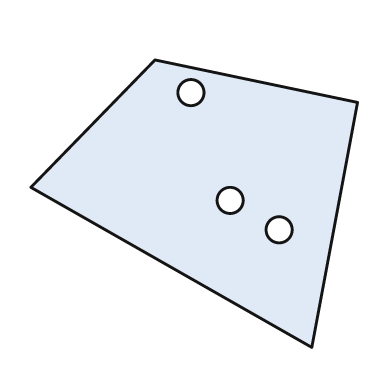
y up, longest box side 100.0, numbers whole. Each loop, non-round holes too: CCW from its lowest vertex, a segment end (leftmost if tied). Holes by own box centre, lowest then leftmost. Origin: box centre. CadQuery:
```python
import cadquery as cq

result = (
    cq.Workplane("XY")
    .moveTo(36.0, -44.0)
    .lineTo(50.0, 31.0)
    .lineTo(-12.0, 44.0)
    .lineTo(-50.0, 5.0)
    .close()
    .moveTo(26.0, -8.0)
    .circle(4.0)
    .moveTo(11.0, 1.0)
    .circle(4.0)
    .moveTo(-1.0, 34.0)
    .circle(4.0)
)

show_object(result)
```